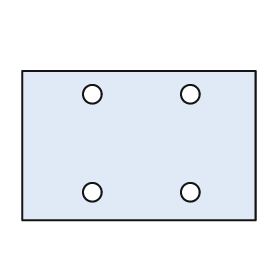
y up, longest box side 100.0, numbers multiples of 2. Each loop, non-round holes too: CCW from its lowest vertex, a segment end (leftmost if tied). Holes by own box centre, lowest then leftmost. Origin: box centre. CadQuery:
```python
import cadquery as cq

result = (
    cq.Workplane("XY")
    .moveTo(-50.0, -32.0)
    .lineTo(50.0, -32.0)
    .lineTo(50.0, 32.0)
    .lineTo(-50.0, 32.0)
    .close()
    .moveTo(-20.0, -20.0)
    .circle(4.0)
    .moveTo(22.0, -20.0)
    .circle(4.0)
    .moveTo(-20.0, 22.0)
    .circle(4.0)
    .moveTo(22.0, 22.0)
    .circle(4.0)
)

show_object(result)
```